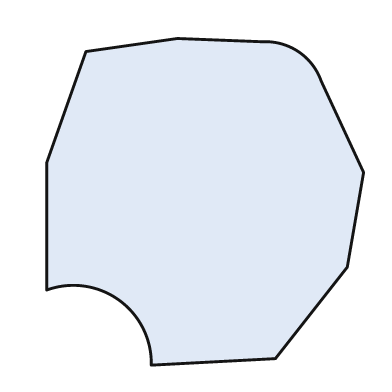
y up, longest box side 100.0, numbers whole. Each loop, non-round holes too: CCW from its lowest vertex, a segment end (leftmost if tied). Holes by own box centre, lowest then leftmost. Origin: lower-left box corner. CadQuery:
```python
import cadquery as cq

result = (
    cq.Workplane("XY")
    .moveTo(32.0, 0.0)
    .lineTo(70.0, 2.0)
    .lineTo(92.0, 30.0)
    .lineTo(97.0, 59.0)
    .lineTo(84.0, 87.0)
    .threePointArc((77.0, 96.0), (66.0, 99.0))
    .lineTo(40.0, 100.0)
    .lineTo(12.0, 96.0)
    .lineTo(0.0, 62.0)
    .lineTo(0.0, 23.0)
    .threePointArc((22.0, 20.0), (32.0, 0.0))
    .close()
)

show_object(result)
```